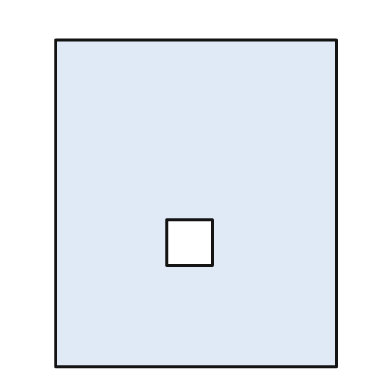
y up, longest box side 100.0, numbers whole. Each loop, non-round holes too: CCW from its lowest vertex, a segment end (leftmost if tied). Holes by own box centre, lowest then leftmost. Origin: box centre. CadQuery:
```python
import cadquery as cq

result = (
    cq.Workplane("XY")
    .moveTo(-43.0, -50.0)
    .lineTo(43.0, -50.0)
    .lineTo(43.0, 50.0)
    .lineTo(-43.0, 50.0)
    .close()
    .moveTo(-9.0, -19.0)
    .lineTo(5.0, -19.0)
    .lineTo(5.0, -5.0)
    .lineTo(-9.0, -5.0)
    .close()
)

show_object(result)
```